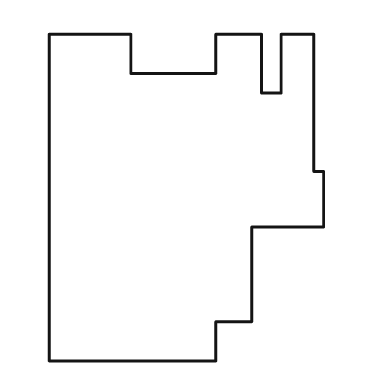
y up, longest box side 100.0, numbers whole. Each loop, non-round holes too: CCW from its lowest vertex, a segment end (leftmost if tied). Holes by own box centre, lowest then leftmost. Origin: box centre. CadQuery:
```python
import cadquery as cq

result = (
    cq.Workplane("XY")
    .moveTo(-42.0, -50.0)
    .lineTo(9.0, -50.0)
    .lineTo(9.0, -38.0)
    .lineTo(20.0, -38.0)
    .lineTo(20.0, -9.0)
    .lineTo(42.0, -9.0)
    .lineTo(42.0, 8.0)
    .lineTo(39.0, 8.0)
    .lineTo(39.0, 50.0)
    .lineTo(29.0, 50.0)
    .lineTo(29.0, 32.0)
    .lineTo(23.0, 32.0)
    .lineTo(23.0, 50.0)
    .lineTo(9.0, 50.0)
    .lineTo(9.0, 38.0)
    .lineTo(-17.0, 38.0)
    .lineTo(-17.0, 50.0)
    .lineTo(-42.0, 50.0)
    .close()
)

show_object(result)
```